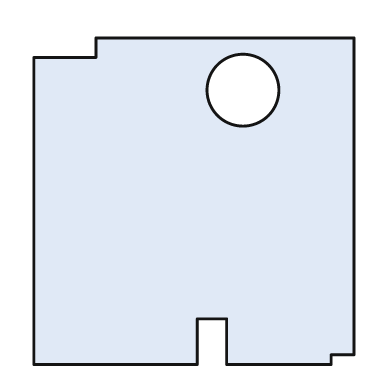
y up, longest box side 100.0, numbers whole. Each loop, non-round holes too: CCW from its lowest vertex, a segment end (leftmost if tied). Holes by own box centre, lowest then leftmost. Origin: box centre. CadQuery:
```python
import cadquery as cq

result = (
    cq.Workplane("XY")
    .moveTo(-49.0, -50.0)
    .lineTo(1.0, -50.0)
    .lineTo(1.0, -36.0)
    .lineTo(10.0, -36.0)
    .lineTo(10.0, -50.0)
    .lineTo(42.0, -50.0)
    .lineTo(42.0, -47.0)
    .lineTo(49.0, -47.0)
    .lineTo(49.0, 50.0)
    .lineTo(-30.0, 50.0)
    .lineTo(-30.0, 44.0)
    .lineTo(-49.0, 44.0)
    .close()
    .moveTo(15.0, 34.0)
    .circle(11.0)
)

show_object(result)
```